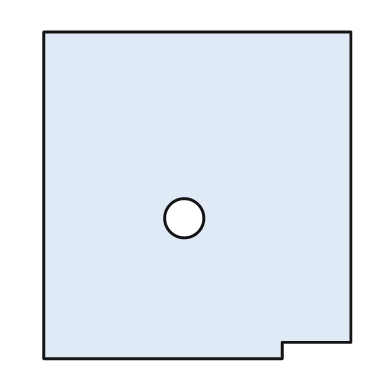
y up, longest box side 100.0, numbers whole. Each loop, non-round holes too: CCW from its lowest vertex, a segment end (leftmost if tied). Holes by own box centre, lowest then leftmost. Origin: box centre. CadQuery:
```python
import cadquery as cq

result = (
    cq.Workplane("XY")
    .moveTo(-47.0, -50.0)
    .lineTo(26.0, -50.0)
    .lineTo(26.0, -45.0)
    .lineTo(47.0, -45.0)
    .lineTo(47.0, 50.0)
    .lineTo(-47.0, 50.0)
    .close()
    .moveTo(-4.0, -7.0)
    .circle(6.0)
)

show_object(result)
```